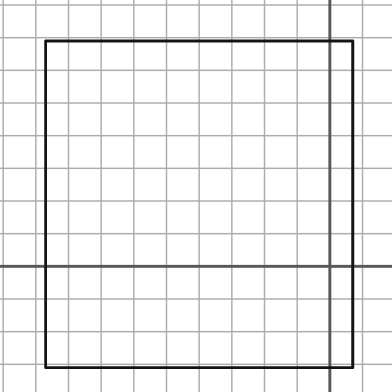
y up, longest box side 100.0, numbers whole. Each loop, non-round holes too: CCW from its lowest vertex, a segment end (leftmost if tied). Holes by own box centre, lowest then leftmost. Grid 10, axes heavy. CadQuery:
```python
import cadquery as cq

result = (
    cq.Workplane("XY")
    .moveTo(-87.0, -31.0)
    .lineTo(7.0, -31.0)
    .lineTo(7.0, 69.0)
    .lineTo(-87.0, 69.0)
    .close()
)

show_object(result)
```